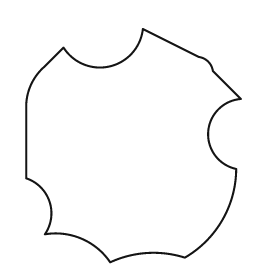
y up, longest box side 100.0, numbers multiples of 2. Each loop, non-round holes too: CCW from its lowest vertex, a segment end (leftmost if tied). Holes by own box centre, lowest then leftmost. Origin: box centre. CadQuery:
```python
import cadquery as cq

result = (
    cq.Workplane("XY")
    .moveTo(-10.0, -50.0)
    .threePointArc((6.0, -46.0), (22.0, -48.0))
    .threePointArc((38.0, -32.0), (44.0, -10.0))
    .threePointArc((32.0, 6.0), (46.0, 20.0))
    .lineTo(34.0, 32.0)
    .threePointArc((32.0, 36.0), (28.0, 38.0))
    .lineTo(4.0, 50.0)
    .threePointArc((-10.0, 34.0), (-30.0, 42.0))
    .lineTo(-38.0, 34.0)
    .threePointArc((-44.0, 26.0), (-46.0, 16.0))
    .lineTo(-46.0, -14.0)
    .threePointArc((-36.0, -24.0), (-38.0, -38.0))
    .threePointArc((-22.0, -40.0), (-10.0, -50.0))
    .close()
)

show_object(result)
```